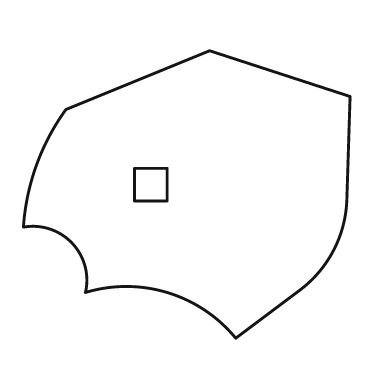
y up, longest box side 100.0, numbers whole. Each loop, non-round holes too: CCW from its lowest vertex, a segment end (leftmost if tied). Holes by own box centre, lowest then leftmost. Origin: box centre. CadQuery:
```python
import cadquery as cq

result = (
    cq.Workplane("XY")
    .moveTo(15.0, -44.0)
    .lineTo(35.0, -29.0)
    .threePointArc((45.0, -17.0), (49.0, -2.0))
    .lineTo(50.0, 30.0)
    .lineTo(7.0, 44.0)
    .lineTo(-37.0, 26.0)
    .threePointArc((-46.0, 9.0), (-50.0, -10.0))
    .threePointArc((-35.0, -15.0), (-31.0, -30.0))
    .threePointArc((-6.0, -30.0), (15.0, -44.0))
    .close()
    .moveTo(-16.0, -2.0)
    .lineTo(-6.0, -2.0)
    .lineTo(-6.0, 8.0)
    .lineTo(-16.0, 8.0)
    .close()
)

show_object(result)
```